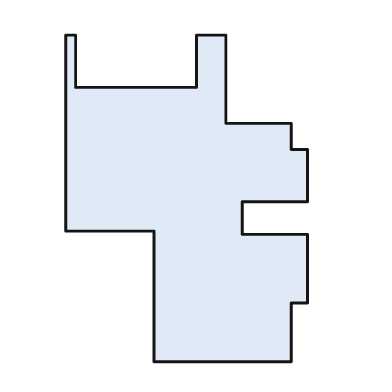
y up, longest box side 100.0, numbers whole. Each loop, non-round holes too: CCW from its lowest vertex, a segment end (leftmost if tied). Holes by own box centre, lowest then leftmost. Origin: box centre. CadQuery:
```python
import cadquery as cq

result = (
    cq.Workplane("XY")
    .moveTo(-10.0, -50.0)
    .lineTo(32.0, -50.0)
    .lineTo(32.0, -32.0)
    .lineTo(37.0, -32.0)
    .lineTo(37.0, -11.0)
    .lineTo(17.0, -11.0)
    .lineTo(17.0, -1.0)
    .lineTo(37.0, -1.0)
    .lineTo(37.0, 15.0)
    .lineTo(32.0, 15.0)
    .lineTo(32.0, 23.0)
    .lineTo(12.0, 23.0)
    .lineTo(12.0, 50.0)
    .lineTo(3.0, 50.0)
    .lineTo(3.0, 34.0)
    .lineTo(-34.0, 34.0)
    .lineTo(-34.0, 50.0)
    .lineTo(-37.0, 50.0)
    .lineTo(-37.0, -10.0)
    .lineTo(-10.0, -10.0)
    .close()
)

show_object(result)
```